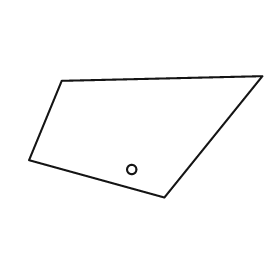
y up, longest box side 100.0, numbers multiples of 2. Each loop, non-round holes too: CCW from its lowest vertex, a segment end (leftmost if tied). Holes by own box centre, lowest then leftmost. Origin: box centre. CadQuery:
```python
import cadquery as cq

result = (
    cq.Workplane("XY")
    .moveTo(8.0, -26.0)
    .lineTo(50.0, 26.0)
    .lineTo(-36.0, 24.0)
    .lineTo(-50.0, -10.0)
    .close()
    .moveTo(-6.0, -14.0)
    .circle(2.0)
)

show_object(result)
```